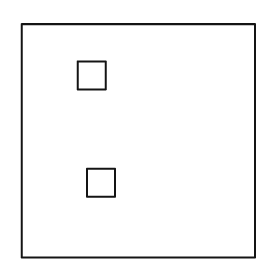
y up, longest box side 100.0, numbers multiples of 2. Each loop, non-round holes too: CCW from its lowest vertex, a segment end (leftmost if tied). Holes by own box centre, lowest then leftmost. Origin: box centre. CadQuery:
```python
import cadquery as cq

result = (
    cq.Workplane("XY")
    .moveTo(-50.0, -50.0)
    .lineTo(50.0, -50.0)
    .lineTo(50.0, 50.0)
    .lineTo(-50.0, 50.0)
    .close()
    .moveTo(-22.0, -24.0)
    .lineTo(-10.0, -24.0)
    .lineTo(-10.0, -12.0)
    .lineTo(-22.0, -12.0)
    .close()
    .moveTo(-26.0, 22.0)
    .lineTo(-14.0, 22.0)
    .lineTo(-14.0, 34.0)
    .lineTo(-26.0, 34.0)
    .close()
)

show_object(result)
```